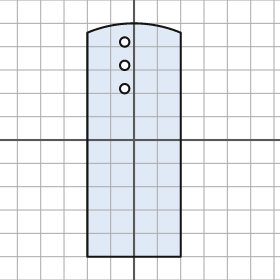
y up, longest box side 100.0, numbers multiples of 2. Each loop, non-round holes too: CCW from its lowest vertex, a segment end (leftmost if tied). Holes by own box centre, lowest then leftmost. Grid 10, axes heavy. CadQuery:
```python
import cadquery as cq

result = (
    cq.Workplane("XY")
    .moveTo(-20.0, -50.0)
    .lineTo(20.0, -50.0)
    .lineTo(20.0, 46.0)
    .threePointArc((0.0, 50.0), (-20.0, 46.0))
    .close()
    .moveTo(-4.0, 22.0)
    .circle(2.0)
    .moveTo(-4.0, 32.0)
    .circle(2.0)
    .moveTo(-4.0, 42.0)
    .circle(2.0)
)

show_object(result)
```